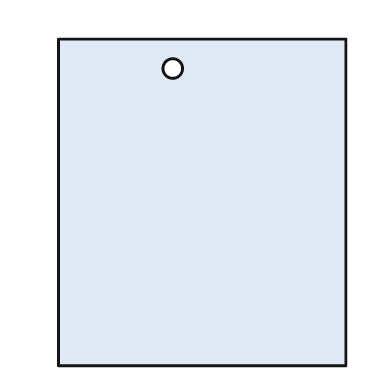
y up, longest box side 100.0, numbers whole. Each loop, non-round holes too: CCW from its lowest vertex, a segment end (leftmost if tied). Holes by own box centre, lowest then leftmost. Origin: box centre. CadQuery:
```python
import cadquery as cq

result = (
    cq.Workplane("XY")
    .moveTo(-44.0, -50.0)
    .lineTo(44.0, -50.0)
    .lineTo(44.0, 50.0)
    .lineTo(-44.0, 50.0)
    .close()
    .moveTo(-9.0, 41.0)
    .circle(3.0)
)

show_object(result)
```